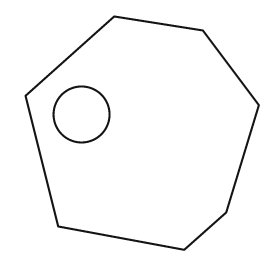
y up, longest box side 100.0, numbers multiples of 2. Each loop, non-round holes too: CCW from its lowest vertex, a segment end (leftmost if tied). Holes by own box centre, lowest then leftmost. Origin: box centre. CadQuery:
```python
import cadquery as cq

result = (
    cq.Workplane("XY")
    .moveTo(18.0, -50.0)
    .lineTo(36.0, -34.0)
    .lineTo(50.0, 12.0)
    .lineTo(26.0, 44.0)
    .lineTo(-12.0, 50.0)
    .lineTo(-50.0, 16.0)
    .lineTo(-36.0, -40.0)
    .close()
    .moveTo(-26.0, 8.0)
    .circle(12.0)
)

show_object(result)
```